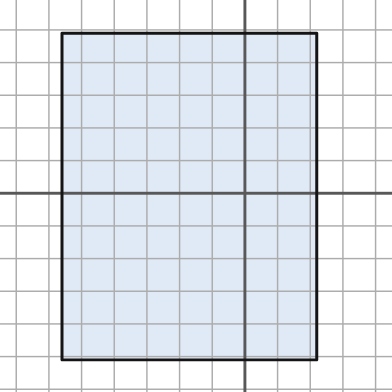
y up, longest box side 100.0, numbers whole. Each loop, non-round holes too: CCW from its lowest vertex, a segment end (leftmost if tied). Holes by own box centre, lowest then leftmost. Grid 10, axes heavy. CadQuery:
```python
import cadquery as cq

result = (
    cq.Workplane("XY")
    .moveTo(-56.0, -51.0)
    .lineTo(22.0, -51.0)
    .lineTo(22.0, 49.0)
    .lineTo(-56.0, 49.0)
    .close()
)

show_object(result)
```